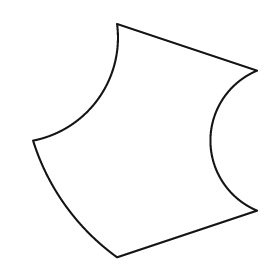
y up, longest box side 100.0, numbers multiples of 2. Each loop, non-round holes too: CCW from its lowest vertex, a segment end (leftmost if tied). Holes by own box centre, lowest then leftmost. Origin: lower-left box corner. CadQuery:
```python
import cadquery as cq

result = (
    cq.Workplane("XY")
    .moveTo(36.0, 0.0)
    .lineTo(96.0, 20.0)
    .threePointArc((76.0, 50.0), (96.0, 80.0))
    .lineTo(36.0, 100.0)
    .threePointArc((28.0, 68.0), (0.0, 50.0))
    .threePointArc((14.0, 22.0), (36.0, 0.0))
    .close()
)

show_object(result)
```